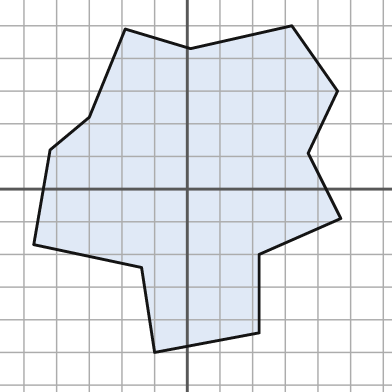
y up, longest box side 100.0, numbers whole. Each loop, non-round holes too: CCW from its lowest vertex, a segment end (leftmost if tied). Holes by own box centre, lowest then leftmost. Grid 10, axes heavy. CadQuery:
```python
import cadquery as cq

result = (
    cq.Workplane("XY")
    .moveTo(-10.0, -50.0)
    .lineTo(22.0, -44.0)
    .lineTo(22.0, -20.0)
    .lineTo(47.0, -9.0)
    .lineTo(37.0, 11.0)
    .lineTo(46.0, 30.0)
    .lineTo(32.0, 50.0)
    .lineTo(1.0, 43.0)
    .lineTo(-19.0, 49.0)
    .lineTo(-30.0, 22.0)
    .lineTo(-42.0, 12.0)
    .lineTo(-47.0, -17.0)
    .lineTo(-14.0, -24.0)
    .close()
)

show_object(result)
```